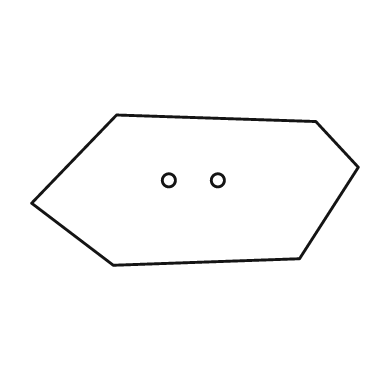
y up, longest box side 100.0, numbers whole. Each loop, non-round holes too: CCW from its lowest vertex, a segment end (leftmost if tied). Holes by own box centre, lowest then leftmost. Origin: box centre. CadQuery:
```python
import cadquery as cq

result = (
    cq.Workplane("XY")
    .moveTo(-25.0, -23.0)
    .lineTo(32.0, -21.0)
    .lineTo(50.0, 7.0)
    .lineTo(37.0, 21.0)
    .lineTo(-24.0, 23.0)
    .lineTo(-50.0, -4.0)
    .close()
    .moveTo(-8.0, 3.0)
    .circle(2.0)
    .moveTo(7.0, 3.0)
    .circle(2.0)
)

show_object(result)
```